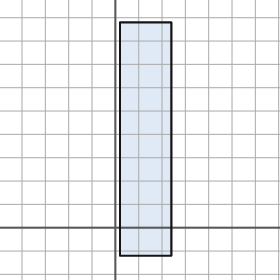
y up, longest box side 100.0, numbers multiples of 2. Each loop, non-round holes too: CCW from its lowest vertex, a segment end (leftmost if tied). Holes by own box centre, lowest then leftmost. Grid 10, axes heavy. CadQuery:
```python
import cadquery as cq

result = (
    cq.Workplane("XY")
    .moveTo(2.0, -12.0)
    .lineTo(24.0, -12.0)
    .lineTo(24.0, 88.0)
    .lineTo(2.0, 88.0)
    .close()
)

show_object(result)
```